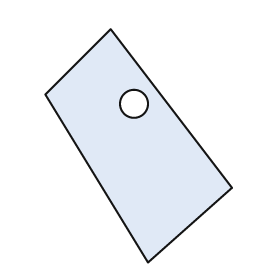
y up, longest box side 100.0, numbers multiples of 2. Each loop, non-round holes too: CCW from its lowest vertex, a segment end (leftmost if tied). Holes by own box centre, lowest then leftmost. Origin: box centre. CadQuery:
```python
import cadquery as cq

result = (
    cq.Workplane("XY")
    .moveTo(4.0, -50.0)
    .lineTo(40.0, -18.0)
    .lineTo(-12.0, 50.0)
    .lineTo(-40.0, 22.0)
    .close()
    .moveTo(-2.0, 18.0)
    .circle(6.0)
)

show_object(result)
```